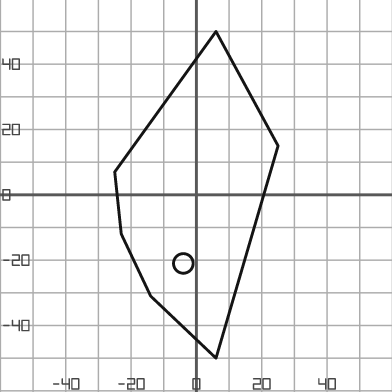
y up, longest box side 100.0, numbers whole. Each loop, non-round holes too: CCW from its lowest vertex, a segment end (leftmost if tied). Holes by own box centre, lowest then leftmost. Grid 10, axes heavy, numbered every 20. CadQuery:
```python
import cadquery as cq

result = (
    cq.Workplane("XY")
    .moveTo(6.0, -50.0)
    .lineTo(25.0, 15.0)
    .lineTo(6.0, 50.0)
    .lineTo(-25.0, 7.0)
    .lineTo(-23.0, -12.0)
    .lineTo(-14.0, -31.0)
    .close()
    .moveTo(-4.0, -21.0)
    .circle(3.0)
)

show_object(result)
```